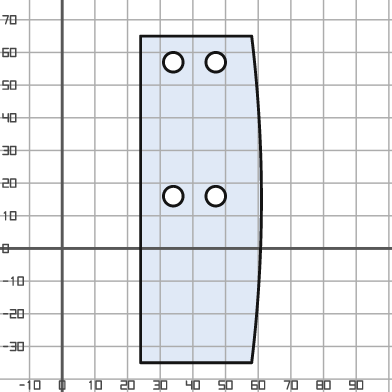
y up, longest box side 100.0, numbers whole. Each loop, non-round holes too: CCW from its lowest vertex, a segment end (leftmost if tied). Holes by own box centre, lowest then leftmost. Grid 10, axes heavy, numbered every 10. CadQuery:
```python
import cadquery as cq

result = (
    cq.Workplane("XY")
    .moveTo(24.0, -35.0)
    .lineTo(58.0, -35.0)
    .threePointArc((61.0, 15.0), (58.0, 65.0))
    .lineTo(24.0, 65.0)
    .close()
    .moveTo(34.0, 16.0)
    .circle(3.0)
    .moveTo(47.0, 16.0)
    .circle(3.0)
    .moveTo(34.0, 57.0)
    .circle(3.0)
    .moveTo(47.0, 57.0)
    .circle(3.0)
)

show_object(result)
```